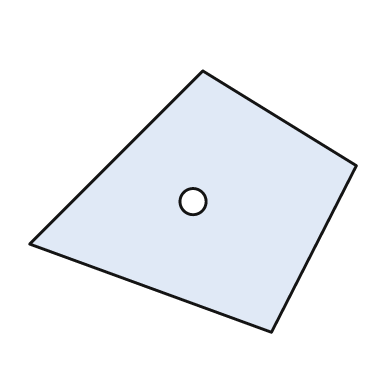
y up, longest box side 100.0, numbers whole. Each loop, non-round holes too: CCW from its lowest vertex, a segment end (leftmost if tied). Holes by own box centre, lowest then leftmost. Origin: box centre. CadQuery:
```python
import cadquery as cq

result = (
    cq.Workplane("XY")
    .moveTo(24.0, -40.0)
    .lineTo(50.0, 11.0)
    .lineTo(3.0, 40.0)
    .lineTo(-50.0, -13.0)
    .close()
    .moveTo(0.0, 0.0)
    .circle(4.0)
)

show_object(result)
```